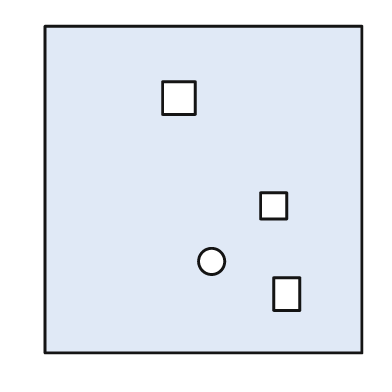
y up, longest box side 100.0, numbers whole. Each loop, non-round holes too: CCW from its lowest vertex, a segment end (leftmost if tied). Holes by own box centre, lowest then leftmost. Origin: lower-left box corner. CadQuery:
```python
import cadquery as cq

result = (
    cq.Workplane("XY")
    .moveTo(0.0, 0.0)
    .lineTo(97.0, 0.0)
    .lineTo(97.0, 100.0)
    .lineTo(0.0, 100.0)
    .close()
    .moveTo(70.0, 13.0)
    .lineTo(78.0, 13.0)
    .lineTo(78.0, 23.0)
    .lineTo(70.0, 23.0)
    .close()
    .moveTo(51.0, 28.0)
    .circle(4.0)
    .moveTo(66.0, 41.0)
    .lineTo(74.0, 41.0)
    .lineTo(74.0, 49.0)
    .lineTo(66.0, 49.0)
    .close()
    .moveTo(36.0, 73.0)
    .lineTo(46.0, 73.0)
    .lineTo(46.0, 83.0)
    .lineTo(36.0, 83.0)
    .close()
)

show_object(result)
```